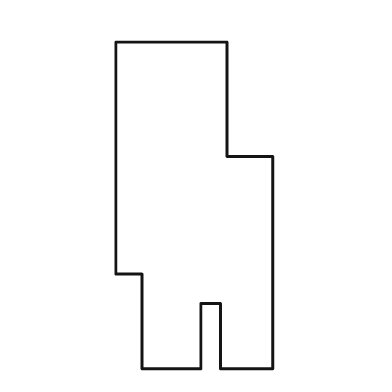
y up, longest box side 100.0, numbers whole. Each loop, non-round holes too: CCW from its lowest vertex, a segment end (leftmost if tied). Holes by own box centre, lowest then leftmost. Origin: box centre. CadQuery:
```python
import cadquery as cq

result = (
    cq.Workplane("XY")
    .moveTo(-16.0, -50.0)
    .lineTo(2.0, -50.0)
    .lineTo(2.0, -30.0)
    .lineTo(8.0, -30.0)
    .lineTo(8.0, -50.0)
    .lineTo(24.0, -50.0)
    .lineTo(24.0, 15.0)
    .lineTo(10.0, 15.0)
    .lineTo(10.0, 50.0)
    .lineTo(-24.0, 50.0)
    .lineTo(-24.0, -21.0)
    .lineTo(-16.0, -21.0)
    .close()
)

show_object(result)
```